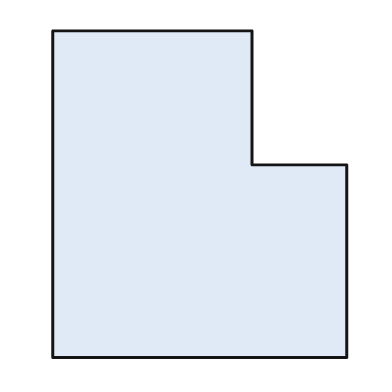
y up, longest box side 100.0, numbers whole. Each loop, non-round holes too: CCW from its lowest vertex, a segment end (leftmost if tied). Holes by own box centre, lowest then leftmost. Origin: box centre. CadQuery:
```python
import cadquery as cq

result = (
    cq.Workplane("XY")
    .moveTo(-45.0, -50.0)
    .lineTo(45.0, -50.0)
    .lineTo(45.0, 9.0)
    .lineTo(16.0, 9.0)
    .lineTo(16.0, 50.0)
    .lineTo(-45.0, 50.0)
    .close()
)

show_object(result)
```